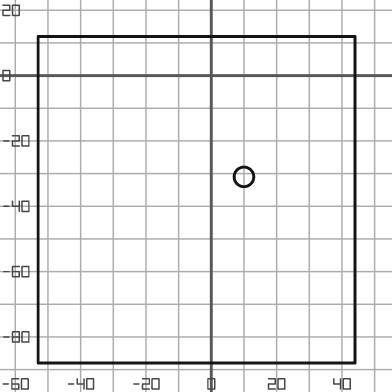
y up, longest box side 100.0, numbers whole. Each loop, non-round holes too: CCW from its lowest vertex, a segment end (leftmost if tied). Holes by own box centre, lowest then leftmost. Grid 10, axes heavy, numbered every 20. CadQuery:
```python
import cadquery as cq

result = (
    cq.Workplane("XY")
    .moveTo(-53.0, -88.0)
    .lineTo(44.0, -88.0)
    .lineTo(44.0, 12.0)
    .lineTo(-53.0, 12.0)
    .close()
    .moveTo(10.0, -31.0)
    .circle(3.0)
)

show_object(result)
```